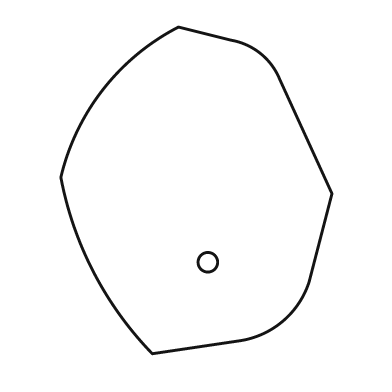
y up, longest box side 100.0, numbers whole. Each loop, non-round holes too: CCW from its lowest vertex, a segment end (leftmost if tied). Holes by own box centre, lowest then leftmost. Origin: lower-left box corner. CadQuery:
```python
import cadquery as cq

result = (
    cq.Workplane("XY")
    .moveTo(28.0, 0.0)
    .lineTo(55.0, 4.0)
    .threePointArc((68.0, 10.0), (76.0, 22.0))
    .lineTo(83.0, 49.0)
    .lineTo(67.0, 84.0)
    .threePointArc((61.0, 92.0), (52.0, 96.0))
    .lineTo(36.0, 100.0)
    .threePointArc((13.0, 81.0), (0.0, 54.0))
    .threePointArc((10.0, 25.0), (28.0, 0.0))
    .close()
    .moveTo(45.0, 28.0)
    .circle(3.0)
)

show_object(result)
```